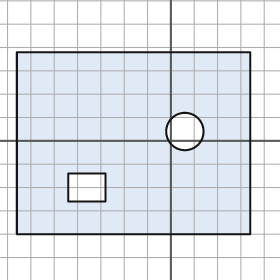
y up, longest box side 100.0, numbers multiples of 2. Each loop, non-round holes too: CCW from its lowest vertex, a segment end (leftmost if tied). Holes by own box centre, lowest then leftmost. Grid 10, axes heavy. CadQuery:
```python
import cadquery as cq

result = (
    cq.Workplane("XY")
    .moveTo(-66.0, -40.0)
    .lineTo(34.0, -40.0)
    .lineTo(34.0, 38.0)
    .lineTo(-66.0, 38.0)
    .close()
    .moveTo(-44.0, -26.0)
    .lineTo(-28.0, -26.0)
    .lineTo(-28.0, -14.0)
    .lineTo(-44.0, -14.0)
    .close()
    .moveTo(6.0, 4.0)
    .circle(8.0)
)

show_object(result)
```